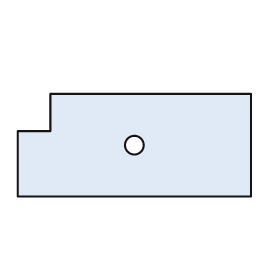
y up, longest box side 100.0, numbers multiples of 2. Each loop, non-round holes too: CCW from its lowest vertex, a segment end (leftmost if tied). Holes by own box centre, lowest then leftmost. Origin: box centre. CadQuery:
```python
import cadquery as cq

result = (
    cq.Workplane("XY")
    .moveTo(-50.0, -22.0)
    .lineTo(50.0, -22.0)
    .lineTo(50.0, 22.0)
    .lineTo(-36.0, 22.0)
    .lineTo(-36.0, 6.0)
    .lineTo(-50.0, 6.0)
    .close()
    .moveTo(0.0, 0.0)
    .circle(4.0)
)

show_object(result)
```